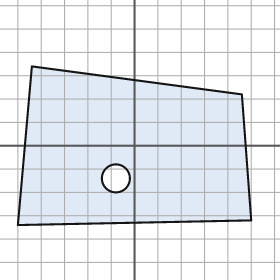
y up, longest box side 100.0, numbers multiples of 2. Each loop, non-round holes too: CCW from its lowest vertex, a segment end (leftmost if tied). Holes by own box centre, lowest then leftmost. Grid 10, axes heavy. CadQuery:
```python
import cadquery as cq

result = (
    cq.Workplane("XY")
    .moveTo(-50.0, -34.0)
    .lineTo(50.0, -32.0)
    .lineTo(46.0, 22.0)
    .lineTo(-44.0, 34.0)
    .close()
    .moveTo(-8.0, -14.0)
    .circle(6.0)
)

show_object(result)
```